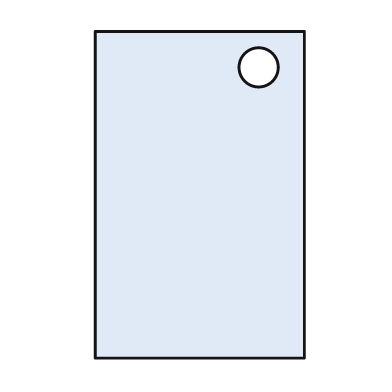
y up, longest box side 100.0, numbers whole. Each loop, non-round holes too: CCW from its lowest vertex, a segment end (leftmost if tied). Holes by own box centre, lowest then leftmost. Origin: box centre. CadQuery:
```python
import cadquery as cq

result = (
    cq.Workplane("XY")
    .moveTo(-32.0, -50.0)
    .lineTo(32.0, -50.0)
    .lineTo(32.0, 50.0)
    .lineTo(-32.0, 50.0)
    .close()
    .moveTo(18.0, 39.0)
    .circle(6.0)
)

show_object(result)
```